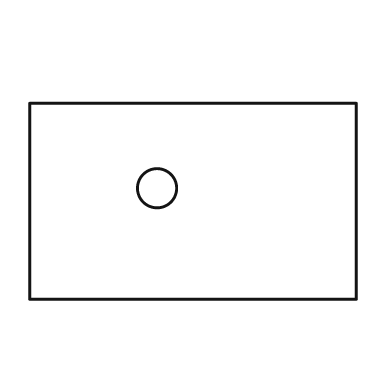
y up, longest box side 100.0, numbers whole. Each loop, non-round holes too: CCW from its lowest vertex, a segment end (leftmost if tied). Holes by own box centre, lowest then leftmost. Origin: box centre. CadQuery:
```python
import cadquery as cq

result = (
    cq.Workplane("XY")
    .moveTo(-50.0, -30.0)
    .lineTo(50.0, -30.0)
    .lineTo(50.0, 30.0)
    .lineTo(-50.0, 30.0)
    .close()
    .moveTo(-11.0, 4.0)
    .circle(6.0)
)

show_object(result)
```